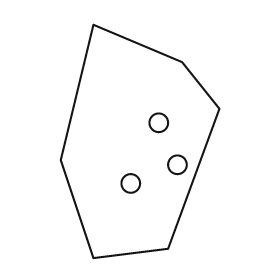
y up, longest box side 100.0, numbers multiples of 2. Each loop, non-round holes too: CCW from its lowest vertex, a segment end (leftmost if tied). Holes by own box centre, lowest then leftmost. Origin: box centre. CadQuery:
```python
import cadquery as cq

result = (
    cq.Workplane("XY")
    .moveTo(-20.0, -50.0)
    .lineTo(12.0, -46.0)
    .lineTo(34.0, 14.0)
    .lineTo(18.0, 34.0)
    .lineTo(-20.0, 50.0)
    .lineTo(-34.0, -8.0)
    .close()
    .moveTo(-4.0, -18.0)
    .circle(4.0)
    .moveTo(16.0, -10.0)
    .circle(4.0)
    .moveTo(8.0, 8.0)
    .circle(4.0)
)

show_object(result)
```